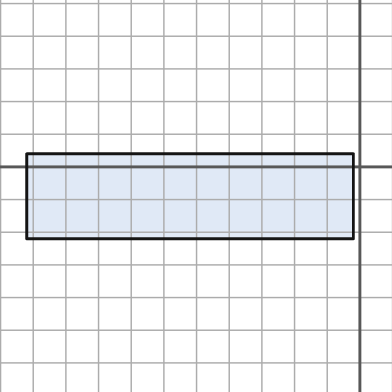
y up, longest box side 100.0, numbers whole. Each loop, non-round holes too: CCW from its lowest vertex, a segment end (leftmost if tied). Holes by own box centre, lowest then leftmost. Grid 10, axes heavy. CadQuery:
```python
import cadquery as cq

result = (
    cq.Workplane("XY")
    .moveTo(-102.0, -22.0)
    .lineTo(-2.0, -22.0)
    .lineTo(-2.0, 4.0)
    .lineTo(-102.0, 4.0)
    .close()
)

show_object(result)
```